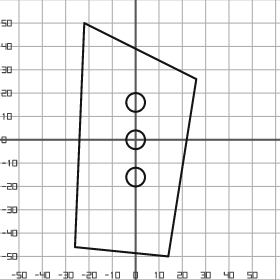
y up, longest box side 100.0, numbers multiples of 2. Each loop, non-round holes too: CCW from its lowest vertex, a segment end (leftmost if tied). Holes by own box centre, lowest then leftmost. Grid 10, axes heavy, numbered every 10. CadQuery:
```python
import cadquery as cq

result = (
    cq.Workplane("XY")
    .moveTo(14.0, -50.0)
    .lineTo(26.0, 26.0)
    .lineTo(-22.0, 50.0)
    .lineTo(-26.0, -46.0)
    .close()
    .moveTo(0.0, -16.0)
    .circle(4.0)
    .moveTo(0.0, 0.0)
    .circle(4.0)
    .moveTo(0.0, 16.0)
    .circle(4.0)
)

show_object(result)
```